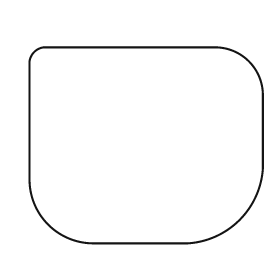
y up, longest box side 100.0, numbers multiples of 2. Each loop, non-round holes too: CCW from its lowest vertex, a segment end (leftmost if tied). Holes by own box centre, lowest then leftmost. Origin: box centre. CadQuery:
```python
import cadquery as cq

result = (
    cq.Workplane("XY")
    .moveTo(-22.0, -42.0)
    .lineTo(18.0, -42.0)
    .threePointArc((40.0, -32.0), (50.0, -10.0))
    .lineTo(50.0, 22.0)
    .threePointArc((44.0, 36.0), (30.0, 42.0))
    .lineTo(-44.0, 42.0)
    .threePointArc((-48.0, 40.0), (-50.0, 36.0))
    .lineTo(-50.0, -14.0)
    .threePointArc((-42.0, -34.0), (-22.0, -42.0))
    .close()
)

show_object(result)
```